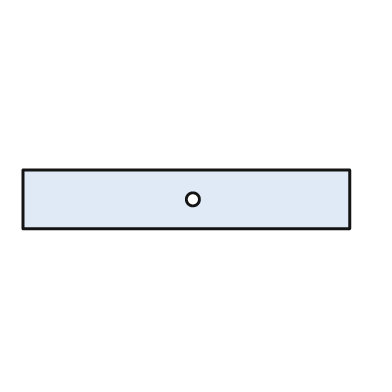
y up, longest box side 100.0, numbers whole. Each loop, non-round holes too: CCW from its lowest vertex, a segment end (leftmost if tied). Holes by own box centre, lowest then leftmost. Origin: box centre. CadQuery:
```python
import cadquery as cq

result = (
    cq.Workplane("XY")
    .moveTo(-50.0, -9.0)
    .lineTo(50.0, -9.0)
    .lineTo(50.0, 9.0)
    .lineTo(-50.0, 9.0)
    .close()
    .moveTo(2.0, 0.0)
    .circle(2.0)
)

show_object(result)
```